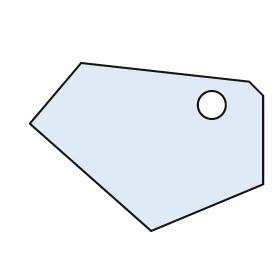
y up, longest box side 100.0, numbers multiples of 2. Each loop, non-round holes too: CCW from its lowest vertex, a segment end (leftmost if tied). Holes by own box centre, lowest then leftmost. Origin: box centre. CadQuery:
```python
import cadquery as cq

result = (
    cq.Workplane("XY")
    .moveTo(2.0, -36.0)
    .lineTo(50.0, -16.0)
    .lineTo(50.0, 22.0)
    .lineTo(44.0, 28.0)
    .lineTo(-28.0, 36.0)
    .lineTo(-50.0, 10.0)
    .close()
    .moveTo(28.0, 18.0)
    .circle(6.0)
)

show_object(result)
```